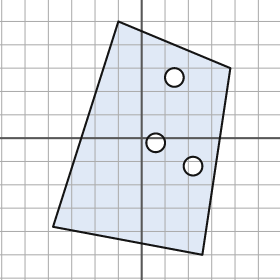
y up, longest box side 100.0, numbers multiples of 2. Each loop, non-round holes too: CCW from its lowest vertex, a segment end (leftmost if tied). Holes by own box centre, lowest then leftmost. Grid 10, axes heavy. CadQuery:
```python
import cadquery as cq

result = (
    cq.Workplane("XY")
    .moveTo(26.0, -50.0)
    .lineTo(38.0, 30.0)
    .lineTo(-10.0, 50.0)
    .lineTo(-38.0, -38.0)
    .close()
    .moveTo(22.0, -12.0)
    .circle(4.0)
    .moveTo(6.0, -2.0)
    .circle(4.0)
    .moveTo(14.0, 26.0)
    .circle(4.0)
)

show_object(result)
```